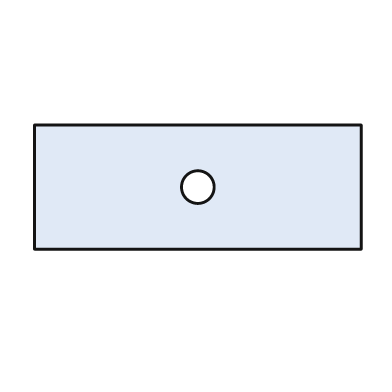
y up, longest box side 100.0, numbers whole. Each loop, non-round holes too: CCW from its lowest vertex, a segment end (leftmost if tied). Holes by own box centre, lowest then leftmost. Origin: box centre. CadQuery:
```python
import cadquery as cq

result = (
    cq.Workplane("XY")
    .moveTo(-50.0, -19.0)
    .lineTo(50.0, -19.0)
    .lineTo(50.0, 19.0)
    .lineTo(-50.0, 19.0)
    .close()
    .moveTo(0.0, 0.0)
    .circle(5.0)
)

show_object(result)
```